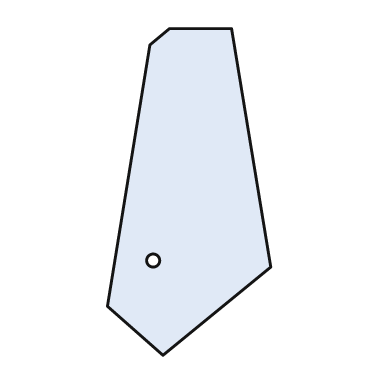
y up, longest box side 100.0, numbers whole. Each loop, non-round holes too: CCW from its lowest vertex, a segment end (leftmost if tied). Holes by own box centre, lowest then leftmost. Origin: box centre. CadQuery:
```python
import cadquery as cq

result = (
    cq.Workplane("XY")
    .moveTo(-8.0, -50.0)
    .lineTo(25.0, -23.0)
    .lineTo(13.0, 50.0)
    .lineTo(-6.0, 50.0)
    .lineTo(-12.0, 45.0)
    .lineTo(-25.0, -35.0)
    .close()
    .moveTo(-11.0, -21.0)
    .circle(2.0)
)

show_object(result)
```